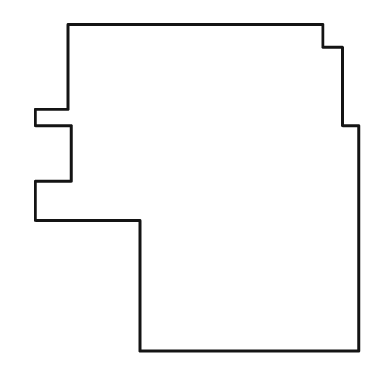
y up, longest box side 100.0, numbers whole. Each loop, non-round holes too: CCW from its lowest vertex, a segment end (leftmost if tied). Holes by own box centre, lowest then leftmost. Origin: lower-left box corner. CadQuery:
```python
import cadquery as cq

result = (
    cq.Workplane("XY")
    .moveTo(32.0, 0.0)
    .lineTo(99.0, 0.0)
    .lineTo(99.0, 69.0)
    .lineTo(94.0, 69.0)
    .lineTo(94.0, 93.0)
    .lineTo(88.0, 93.0)
    .lineTo(88.0, 100.0)
    .lineTo(10.0, 100.0)
    .lineTo(10.0, 74.0)
    .lineTo(0.0, 74.0)
    .lineTo(0.0, 69.0)
    .lineTo(11.0, 69.0)
    .lineTo(11.0, 52.0)
    .lineTo(0.0, 52.0)
    .lineTo(0.0, 40.0)
    .lineTo(32.0, 40.0)
    .close()
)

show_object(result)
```